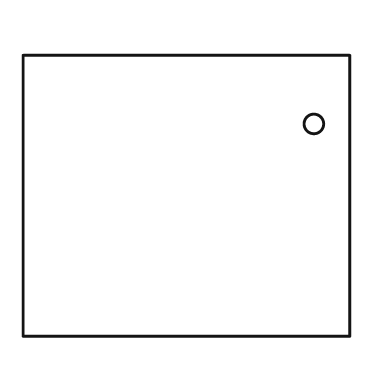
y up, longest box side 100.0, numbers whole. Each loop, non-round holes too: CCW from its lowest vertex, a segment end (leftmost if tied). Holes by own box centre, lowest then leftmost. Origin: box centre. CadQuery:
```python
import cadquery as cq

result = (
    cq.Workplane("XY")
    .moveTo(-50.0, -43.0)
    .lineTo(50.0, -43.0)
    .lineTo(50.0, 43.0)
    .lineTo(-50.0, 43.0)
    .close()
    .moveTo(39.0, 22.0)
    .circle(3.0)
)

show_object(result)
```